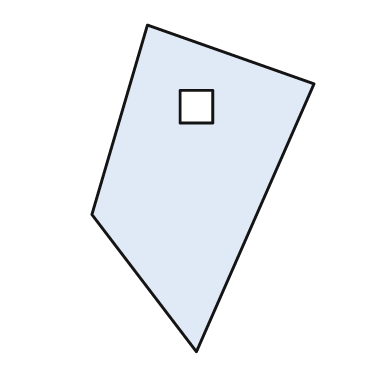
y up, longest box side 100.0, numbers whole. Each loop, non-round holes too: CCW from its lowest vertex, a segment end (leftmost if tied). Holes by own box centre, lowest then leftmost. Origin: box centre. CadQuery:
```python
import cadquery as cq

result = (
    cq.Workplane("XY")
    .moveTo(-2.0, -50.0)
    .lineTo(34.0, 32.0)
    .lineTo(-17.0, 50.0)
    .lineTo(-34.0, -8.0)
    .close()
    .moveTo(-7.0, 20.0)
    .lineTo(3.0, 20.0)
    .lineTo(3.0, 30.0)
    .lineTo(-7.0, 30.0)
    .close()
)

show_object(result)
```